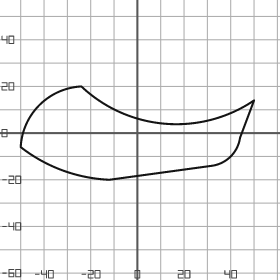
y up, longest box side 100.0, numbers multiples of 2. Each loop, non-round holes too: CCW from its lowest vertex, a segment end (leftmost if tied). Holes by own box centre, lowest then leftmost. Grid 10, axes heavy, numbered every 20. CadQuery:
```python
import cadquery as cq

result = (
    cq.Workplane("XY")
    .moveTo(-12.0, -20.0)
    .lineTo(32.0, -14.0)
    .threePointArc((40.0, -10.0), (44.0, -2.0))
    .lineTo(50.0, 14.0)
    .threePointArc((12.0, 4.0), (-24.0, 20.0))
    .threePointArc((-42.0, 12.0), (-50.0, -6.0))
    .threePointArc((-32.0, -16.0), (-12.0, -20.0))
    .close()
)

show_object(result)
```